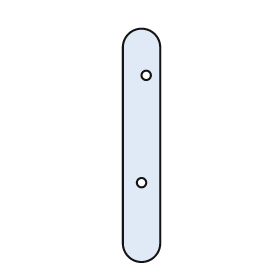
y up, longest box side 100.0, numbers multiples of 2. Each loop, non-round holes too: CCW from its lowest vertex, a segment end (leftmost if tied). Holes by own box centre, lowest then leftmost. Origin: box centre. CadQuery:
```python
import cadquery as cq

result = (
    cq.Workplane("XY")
    .moveTo(-8.0, -42.0)
    .threePointArc((0.0, -50.0), (8.0, -42.0))
    .lineTo(8.0, 42.0)
    .threePointArc((0.0, 50.0), (-8.0, 42.0))
    .close()
    .moveTo(0.0, -16.0)
    .circle(2.0)
    .moveTo(2.0, 30.0)
    .circle(2.0)
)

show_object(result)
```